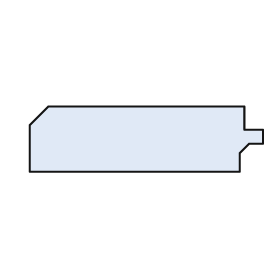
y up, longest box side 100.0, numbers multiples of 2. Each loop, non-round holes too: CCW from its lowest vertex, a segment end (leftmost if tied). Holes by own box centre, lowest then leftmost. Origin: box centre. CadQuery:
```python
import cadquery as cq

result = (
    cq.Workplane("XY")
    .moveTo(-50.0, -14.0)
    .lineTo(40.0, -14.0)
    .lineTo(40.0, -6.0)
    .lineTo(44.0, -2.0)
    .lineTo(50.0, -2.0)
    .lineTo(50.0, 4.0)
    .lineTo(42.0, 4.0)
    .lineTo(42.0, 14.0)
    .lineTo(-42.0, 14.0)
    .lineTo(-50.0, 6.0)
    .close()
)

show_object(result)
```